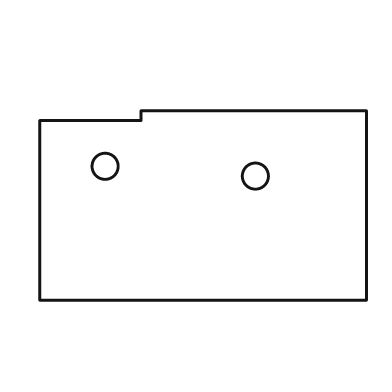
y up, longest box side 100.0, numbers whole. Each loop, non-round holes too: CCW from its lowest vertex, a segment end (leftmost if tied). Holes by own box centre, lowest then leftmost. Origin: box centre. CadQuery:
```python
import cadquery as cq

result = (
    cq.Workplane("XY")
    .moveTo(-50.0, -29.0)
    .lineTo(50.0, -29.0)
    .lineTo(50.0, 29.0)
    .lineTo(-19.0, 29.0)
    .lineTo(-19.0, 26.0)
    .lineTo(-50.0, 26.0)
    .close()
    .moveTo(16.0, 9.0)
    .circle(4.0)
    .moveTo(-30.0, 12.0)
    .circle(4.0)
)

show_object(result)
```